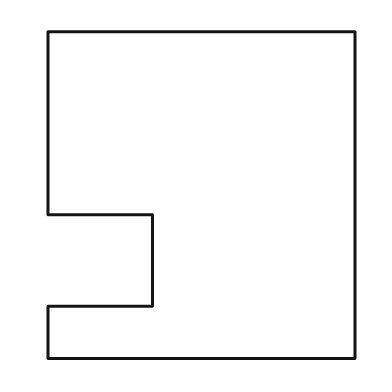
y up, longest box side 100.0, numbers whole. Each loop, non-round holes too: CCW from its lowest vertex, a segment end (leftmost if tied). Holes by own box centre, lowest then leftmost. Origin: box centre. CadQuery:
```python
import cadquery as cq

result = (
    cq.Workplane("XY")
    .moveTo(-47.0, -50.0)
    .lineTo(47.0, -50.0)
    .lineTo(47.0, 50.0)
    .lineTo(-47.0, 50.0)
    .lineTo(-47.0, -6.0)
    .lineTo(-15.0, -6.0)
    .lineTo(-15.0, -34.0)
    .lineTo(-47.0, -34.0)
    .close()
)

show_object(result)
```